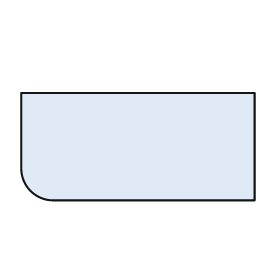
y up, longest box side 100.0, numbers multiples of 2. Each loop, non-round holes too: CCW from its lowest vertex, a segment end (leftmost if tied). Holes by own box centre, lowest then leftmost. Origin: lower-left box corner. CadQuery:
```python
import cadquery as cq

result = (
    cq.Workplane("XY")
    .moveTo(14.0, 0.0)
    .lineTo(100.0, 0.0)
    .lineTo(100.0, 46.0)
    .lineTo(0.0, 46.0)
    .lineTo(0.0, 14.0)
    .threePointArc((4.0, 4.0), (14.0, 0.0))
    .close()
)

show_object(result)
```